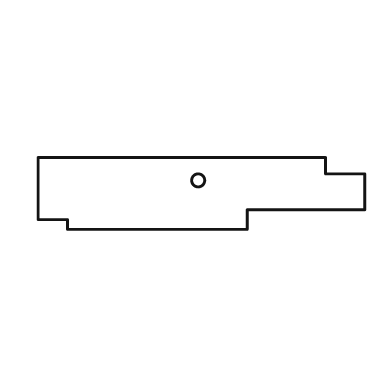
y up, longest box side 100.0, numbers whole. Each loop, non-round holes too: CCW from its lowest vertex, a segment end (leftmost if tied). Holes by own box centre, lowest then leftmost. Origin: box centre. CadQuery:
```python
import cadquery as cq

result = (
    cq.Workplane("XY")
    .moveTo(-41.0, -11.0)
    .lineTo(14.0, -11.0)
    .lineTo(14.0, -5.0)
    .lineTo(50.0, -5.0)
    .lineTo(50.0, 6.0)
    .lineTo(38.0, 6.0)
    .lineTo(38.0, 11.0)
    .lineTo(-50.0, 11.0)
    .lineTo(-50.0, -8.0)
    .lineTo(-41.0, -8.0)
    .close()
    .moveTo(-1.0, 4.0)
    .circle(2.0)
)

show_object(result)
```